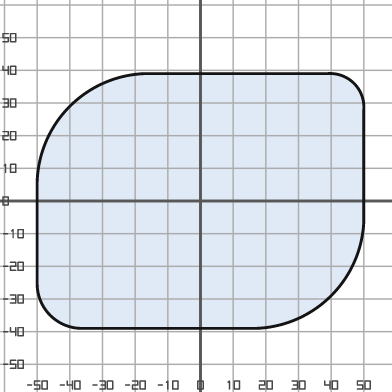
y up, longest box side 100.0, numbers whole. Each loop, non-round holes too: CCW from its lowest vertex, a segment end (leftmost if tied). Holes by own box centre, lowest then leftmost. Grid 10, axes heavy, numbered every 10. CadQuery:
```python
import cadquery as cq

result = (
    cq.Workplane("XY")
    .moveTo(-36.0, -39.0)
    .lineTo(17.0, -39.0)
    .threePointArc((40.0, -29.0), (50.0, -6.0))
    .lineTo(50.0, 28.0)
    .threePointArc((47.0, 36.0), (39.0, 39.0))
    .lineTo(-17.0, 39.0)
    .threePointArc((-40.0, 29.0), (-50.0, 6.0))
    .lineTo(-50.0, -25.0)
    .threePointArc((-46.0, -35.0), (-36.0, -39.0))
    .close()
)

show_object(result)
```